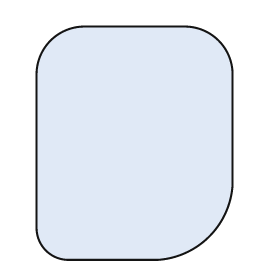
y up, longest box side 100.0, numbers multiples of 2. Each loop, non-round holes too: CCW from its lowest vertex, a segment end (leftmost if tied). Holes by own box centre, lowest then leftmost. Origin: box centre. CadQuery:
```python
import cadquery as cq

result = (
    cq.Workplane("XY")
    .moveTo(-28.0, -50.0)
    .lineTo(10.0, -50.0)
    .threePointArc((32.0, -40.0), (42.0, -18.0))
    .lineTo(42.0, 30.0)
    .threePointArc((36.0, 44.0), (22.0, 50.0))
    .lineTo(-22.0, 50.0)
    .threePointArc((-36.0, 44.0), (-42.0, 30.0))
    .lineTo(-42.0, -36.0)
    .threePointArc((-38.0, -46.0), (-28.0, -50.0))
    .close()
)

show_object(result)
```